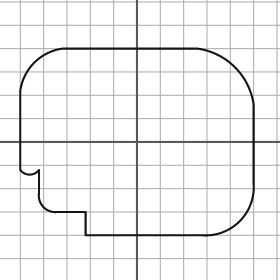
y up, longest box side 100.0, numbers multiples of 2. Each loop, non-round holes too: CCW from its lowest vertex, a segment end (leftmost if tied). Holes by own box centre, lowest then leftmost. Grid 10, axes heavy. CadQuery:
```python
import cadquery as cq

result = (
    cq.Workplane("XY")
    .moveTo(-22.0, -40.0)
    .lineTo(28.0, -40.0)
    .threePointArc((44.0, -34.0), (50.0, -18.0))
    .lineTo(50.0, 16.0)
    .threePointArc((42.0, 32.0), (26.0, 40.0))
    .lineTo(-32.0, 40.0)
    .threePointArc((-44.0, 34.0), (-50.0, 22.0))
    .lineTo(-50.0, -12.0)
    .threePointArc((-46.0, -14.0), (-42.0, -12.0))
    .lineTo(-42.0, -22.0)
    .threePointArc((-40.0, -28.0), (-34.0, -30.0))
    .lineTo(-22.0, -30.0)
    .close()
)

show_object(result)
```